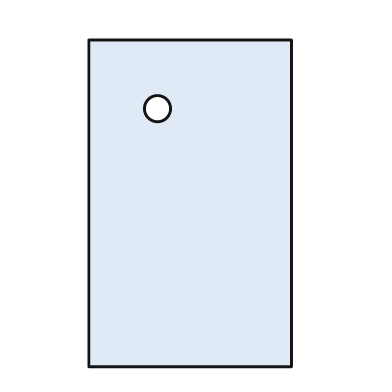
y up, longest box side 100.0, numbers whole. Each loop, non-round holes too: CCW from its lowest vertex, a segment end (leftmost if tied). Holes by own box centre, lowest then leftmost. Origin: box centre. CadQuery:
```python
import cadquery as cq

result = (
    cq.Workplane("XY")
    .moveTo(-31.0, -50.0)
    .lineTo(31.0, -50.0)
    .lineTo(31.0, 50.0)
    .lineTo(-31.0, 50.0)
    .close()
    .moveTo(-10.0, 29.0)
    .circle(4.0)
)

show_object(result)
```